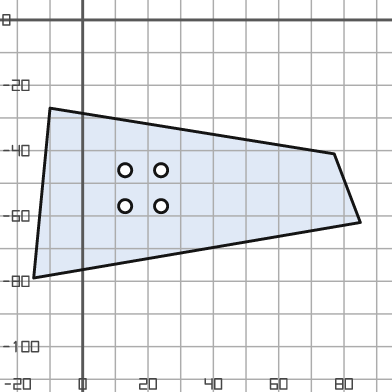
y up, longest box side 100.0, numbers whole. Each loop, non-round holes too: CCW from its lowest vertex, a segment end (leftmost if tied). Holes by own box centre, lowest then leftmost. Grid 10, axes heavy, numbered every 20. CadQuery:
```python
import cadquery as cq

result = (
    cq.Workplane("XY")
    .moveTo(-15.0, -79.0)
    .lineTo(85.0, -62.0)
    .lineTo(77.0, -41.0)
    .lineTo(-10.0, -27.0)
    .close()
    .moveTo(13.0, -57.0)
    .circle(2.0)
    .moveTo(24.0, -57.0)
    .circle(2.0)
    .moveTo(13.0, -46.0)
    .circle(2.0)
    .moveTo(24.0, -46.0)
    .circle(2.0)
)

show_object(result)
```